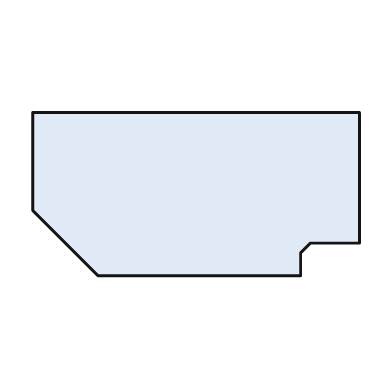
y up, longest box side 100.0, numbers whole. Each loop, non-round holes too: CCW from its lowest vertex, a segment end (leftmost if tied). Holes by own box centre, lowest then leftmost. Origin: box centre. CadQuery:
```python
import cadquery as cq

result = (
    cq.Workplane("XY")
    .moveTo(-30.0, -25.0)
    .lineTo(32.0, -25.0)
    .lineTo(32.0, -18.0)
    .lineTo(35.0, -15.0)
    .lineTo(50.0, -15.0)
    .lineTo(50.0, 25.0)
    .lineTo(-50.0, 25.0)
    .lineTo(-50.0, -5.0)
    .close()
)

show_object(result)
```